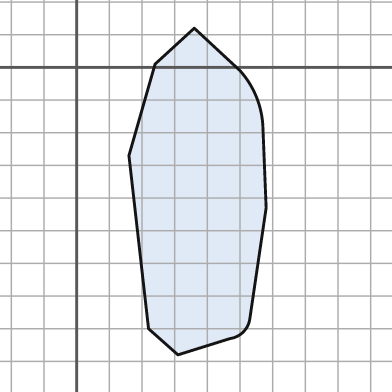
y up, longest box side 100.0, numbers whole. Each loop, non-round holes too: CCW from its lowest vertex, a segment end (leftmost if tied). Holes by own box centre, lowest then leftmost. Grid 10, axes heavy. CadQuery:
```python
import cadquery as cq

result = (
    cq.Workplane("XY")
    .moveTo(31.0, -88.0)
    .lineTo(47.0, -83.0)
    .threePointArc((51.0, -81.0), (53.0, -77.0))
    .lineTo(58.0, -43.0)
    .lineTo(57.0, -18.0)
    .threePointArc((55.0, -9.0), (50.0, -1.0))
    .lineTo(36.0, 12.0)
    .lineTo(24.0, 1.0)
    .lineTo(16.0, -27.0)
    .lineTo(22.0, -80.0)
    .close()
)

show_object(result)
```